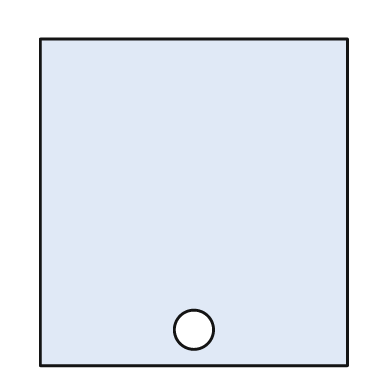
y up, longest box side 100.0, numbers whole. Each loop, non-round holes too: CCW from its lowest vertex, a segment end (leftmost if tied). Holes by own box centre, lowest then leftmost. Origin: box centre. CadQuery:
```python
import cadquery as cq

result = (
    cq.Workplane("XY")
    .moveTo(-47.0, -50.0)
    .lineTo(47.0, -50.0)
    .lineTo(47.0, 50.0)
    .lineTo(-47.0, 50.0)
    .close()
    .moveTo(0.0, -39.0)
    .circle(6.0)
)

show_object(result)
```